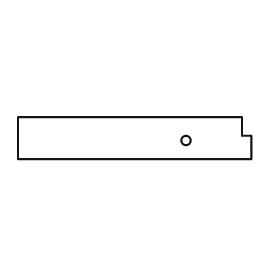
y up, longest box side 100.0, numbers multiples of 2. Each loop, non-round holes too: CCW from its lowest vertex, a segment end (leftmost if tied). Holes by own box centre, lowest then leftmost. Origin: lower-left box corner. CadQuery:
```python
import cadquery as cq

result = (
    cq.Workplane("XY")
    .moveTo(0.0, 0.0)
    .lineTo(100.0, 0.0)
    .lineTo(100.0, 10.0)
    .lineTo(96.0, 10.0)
    .lineTo(96.0, 18.0)
    .lineTo(0.0, 18.0)
    .close()
    .moveTo(72.0, 8.0)
    .circle(2.0)
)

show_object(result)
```